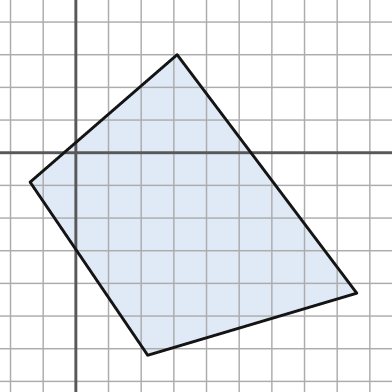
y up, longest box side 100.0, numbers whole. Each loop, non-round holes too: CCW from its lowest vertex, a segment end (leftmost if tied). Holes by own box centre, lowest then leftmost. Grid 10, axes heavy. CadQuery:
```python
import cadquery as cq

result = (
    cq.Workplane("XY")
    .moveTo(22.0, -62.0)
    .lineTo(86.0, -43.0)
    .lineTo(31.0, 30.0)
    .lineTo(-14.0, -9.0)
    .close()
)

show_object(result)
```